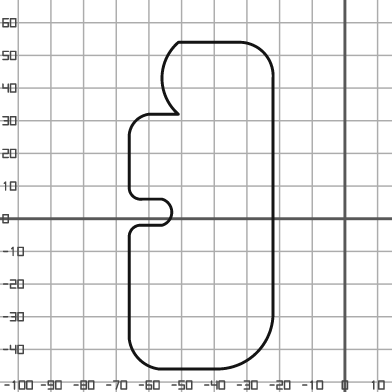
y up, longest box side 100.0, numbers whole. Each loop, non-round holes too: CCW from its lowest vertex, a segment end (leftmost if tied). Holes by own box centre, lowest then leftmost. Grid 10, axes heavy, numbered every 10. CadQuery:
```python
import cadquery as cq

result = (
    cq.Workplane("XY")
    .moveTo(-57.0, -46.0)
    .lineTo(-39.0, -46.0)
    .threePointArc((-27.0, -41.0), (-22.0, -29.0))
    .lineTo(-22.0, 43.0)
    .threePointArc((-25.0, 51.0), (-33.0, 54.0))
    .lineTo(-51.0, 54.0)
    .threePointArc((-56.0, 43.0), (-51.0, 32.0))
    .lineTo(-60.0, 32.0)
    .threePointArc((-64.0, 30.0), (-66.0, 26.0))
    .lineTo(-66.0, 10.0)
    .threePointArc((-65.0, 7.0), (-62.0, 6.0))
    .lineTo(-56.0, 6.0)
    .threePointArc((-53.0, 2.0), (-56.0, -2.0))
    .lineTo(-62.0, -2.0)
    .threePointArc((-65.0, -3.0), (-66.0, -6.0))
    .lineTo(-66.0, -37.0)
    .threePointArc((-63.0, -43.0), (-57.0, -46.0))
    .close()
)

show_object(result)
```